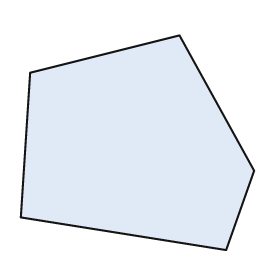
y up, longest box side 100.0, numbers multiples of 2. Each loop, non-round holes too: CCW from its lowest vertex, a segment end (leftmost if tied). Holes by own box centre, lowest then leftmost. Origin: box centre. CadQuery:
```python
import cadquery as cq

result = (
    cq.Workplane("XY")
    .moveTo(38.0, -46.0)
    .lineTo(50.0, -12.0)
    .lineTo(18.0, 46.0)
    .lineTo(-46.0, 30.0)
    .lineTo(-50.0, -32.0)
    .close()
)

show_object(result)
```